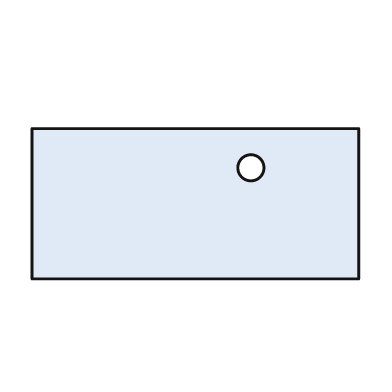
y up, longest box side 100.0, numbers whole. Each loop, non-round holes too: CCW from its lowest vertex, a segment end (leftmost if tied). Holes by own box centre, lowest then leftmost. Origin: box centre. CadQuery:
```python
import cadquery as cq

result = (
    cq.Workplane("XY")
    .moveTo(-50.0, -23.0)
    .lineTo(50.0, -23.0)
    .lineTo(50.0, 23.0)
    .lineTo(-50.0, 23.0)
    .close()
    .moveTo(17.0, 11.0)
    .circle(4.0)
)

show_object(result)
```